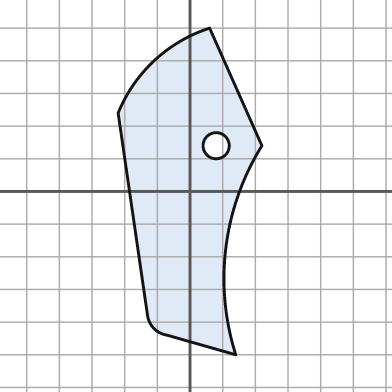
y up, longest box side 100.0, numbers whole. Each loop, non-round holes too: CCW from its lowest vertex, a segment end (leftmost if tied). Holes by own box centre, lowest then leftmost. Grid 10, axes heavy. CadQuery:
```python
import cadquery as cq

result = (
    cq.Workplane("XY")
    .moveTo(14.0, -50.0)
    .threePointArc((11.0, -17.0), (22.0, 14.0))
    .lineTo(6.0, 50.0)
    .threePointArc((-11.0, 40.0), (-22.0, 24.0))
    .lineTo(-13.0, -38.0)
    .threePointArc((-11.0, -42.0), (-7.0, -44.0))
    .close()
    .moveTo(8.0, 14.0)
    .circle(4.0)
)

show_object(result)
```